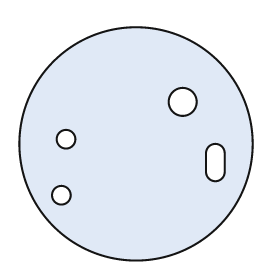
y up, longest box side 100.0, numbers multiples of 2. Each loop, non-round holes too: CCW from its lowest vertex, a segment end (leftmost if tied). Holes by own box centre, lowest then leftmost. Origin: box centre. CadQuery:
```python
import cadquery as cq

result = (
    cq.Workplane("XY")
    .moveTo(0.0, 0.0)
    .circle(50.0)
    .moveTo(-32.0, -22.0)
    .circle(4.0)
    .moveTo(30.0, -12.0)
    .threePointArc((34.0, -16.0), (38.0, -12.0))
    .lineTo(38.0, -4.0)
    .threePointArc((34.0, 0.0), (30.0, -4.0))
    .close()
    .moveTo(-30.0, 2.0)
    .circle(4.0)
    .moveTo(20.0, 18.0)
    .circle(6.0)
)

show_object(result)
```